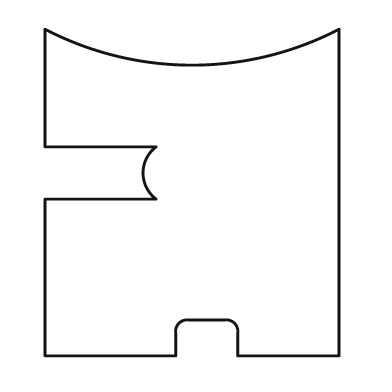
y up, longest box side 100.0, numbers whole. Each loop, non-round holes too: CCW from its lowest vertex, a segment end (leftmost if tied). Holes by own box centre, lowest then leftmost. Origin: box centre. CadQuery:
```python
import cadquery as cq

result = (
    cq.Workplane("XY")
    .moveTo(-45.0, -50.0)
    .lineTo(-5.0, -50.0)
    .lineTo(-5.0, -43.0)
    .threePointArc((-4.0, -40.0), (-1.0, -39.0))
    .lineTo(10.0, -39.0)
    .threePointArc((13.0, -40.0), (14.0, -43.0))
    .lineTo(14.0, -50.0)
    .lineTo(45.0, -50.0)
    .lineTo(45.0, 50.0)
    .threePointArc((0.0, 39.0), (-45.0, 50.0))
    .lineTo(-45.0, 14.0)
    .lineTo(-11.0, 14.0)
    .threePointArc((-15.0, 6.0), (-11.0, -2.0))
    .lineTo(-45.0, -2.0)
    .close()
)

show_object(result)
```